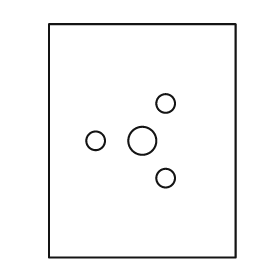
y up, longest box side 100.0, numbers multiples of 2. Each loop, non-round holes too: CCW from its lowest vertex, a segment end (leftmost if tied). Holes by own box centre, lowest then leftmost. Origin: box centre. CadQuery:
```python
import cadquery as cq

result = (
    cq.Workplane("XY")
    .moveTo(-40.0, -50.0)
    .lineTo(40.0, -50.0)
    .lineTo(40.0, 50.0)
    .lineTo(-40.0, 50.0)
    .close()
    .moveTo(10.0, -16.0)
    .circle(4.0)
    .moveTo(-20.0, 0.0)
    .circle(4.0)
    .moveTo(0.0, 0.0)
    .circle(6.0)
    .moveTo(10.0, 16.0)
    .circle(4.0)
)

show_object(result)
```